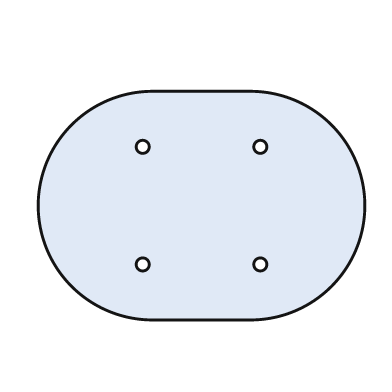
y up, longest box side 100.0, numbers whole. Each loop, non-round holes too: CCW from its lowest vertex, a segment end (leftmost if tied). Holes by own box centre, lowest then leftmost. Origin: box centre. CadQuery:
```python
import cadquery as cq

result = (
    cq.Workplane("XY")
    .moveTo(-15.0, -35.0)
    .lineTo(15.0, -35.0)
    .threePointArc((50.0, 0.0), (15.0, 35.0))
    .lineTo(-15.0, 35.0)
    .threePointArc((-50.0, 0.0), (-15.0, -35.0))
    .close()
    .moveTo(-18.0, -18.0)
    .circle(2.0)
    .moveTo(18.0, -18.0)
    .circle(2.0)
    .moveTo(-18.0, 18.0)
    .circle(2.0)
    .moveTo(18.0, 18.0)
    .circle(2.0)
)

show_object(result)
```